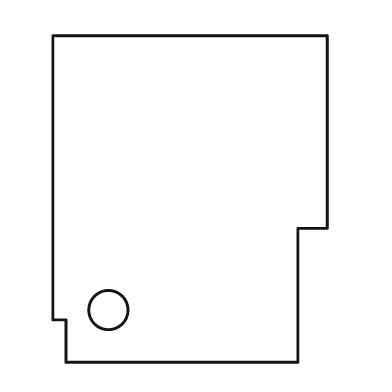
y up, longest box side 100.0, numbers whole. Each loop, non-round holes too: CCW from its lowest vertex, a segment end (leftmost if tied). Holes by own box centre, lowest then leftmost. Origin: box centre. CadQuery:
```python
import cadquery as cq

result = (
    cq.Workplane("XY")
    .moveTo(-38.0, -50.0)
    .lineTo(33.0, -50.0)
    .lineTo(33.0, -9.0)
    .lineTo(42.0, -9.0)
    .lineTo(42.0, 50.0)
    .lineTo(-42.0, 50.0)
    .lineTo(-42.0, -37.0)
    .lineTo(-38.0, -37.0)
    .close()
    .moveTo(-25.0, -34.0)
    .circle(6.0)
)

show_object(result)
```